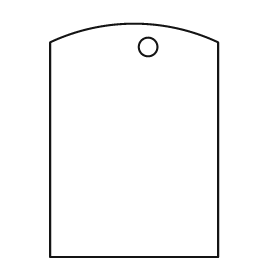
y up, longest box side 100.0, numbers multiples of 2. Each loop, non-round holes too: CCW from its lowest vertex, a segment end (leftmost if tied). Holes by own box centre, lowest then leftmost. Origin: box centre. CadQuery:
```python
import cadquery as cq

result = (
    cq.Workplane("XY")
    .moveTo(-36.0, -50.0)
    .lineTo(36.0, -50.0)
    .lineTo(36.0, 42.0)
    .threePointArc((0.0, 50.0), (-36.0, 42.0))
    .close()
    .moveTo(6.0, 40.0)
    .circle(4.0)
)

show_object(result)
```